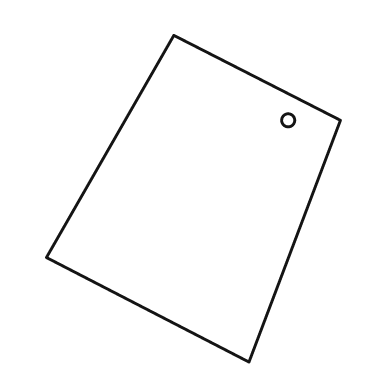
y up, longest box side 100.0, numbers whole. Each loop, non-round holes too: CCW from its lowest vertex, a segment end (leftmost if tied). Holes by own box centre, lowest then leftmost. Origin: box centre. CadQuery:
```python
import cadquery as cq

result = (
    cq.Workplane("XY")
    .moveTo(17.0, -50.0)
    .lineTo(45.0, 24.0)
    .lineTo(-6.0, 50.0)
    .lineTo(-45.0, -18.0)
    .close()
    .moveTo(29.0, 24.0)
    .circle(2.0)
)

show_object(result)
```